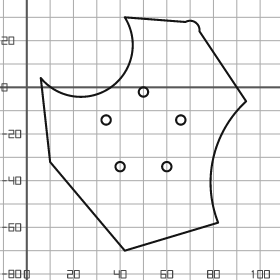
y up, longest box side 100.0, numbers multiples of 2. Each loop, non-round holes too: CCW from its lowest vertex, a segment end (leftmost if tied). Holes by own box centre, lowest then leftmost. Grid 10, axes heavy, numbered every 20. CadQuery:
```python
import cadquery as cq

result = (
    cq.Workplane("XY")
    .moveTo(42.0, -70.0)
    .lineTo(82.0, -58.0)
    .threePointArc((80.0, -30.0), (94.0, -6.0))
    .lineTo(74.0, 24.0)
    .threePointArc((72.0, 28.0), (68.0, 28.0))
    .lineTo(42.0, 30.0)
    .threePointArc((36.0, 0.0), (6.0, 4.0))
    .lineTo(10.0, -32.0)
    .close()
    .moveTo(40.0, -34.0)
    .circle(2.0)
    .moveTo(60.0, -34.0)
    .circle(2.0)
    .moveTo(34.0, -14.0)
    .circle(2.0)
    .moveTo(66.0, -14.0)
    .circle(2.0)
    .moveTo(50.0, -2.0)
    .circle(2.0)
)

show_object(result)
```